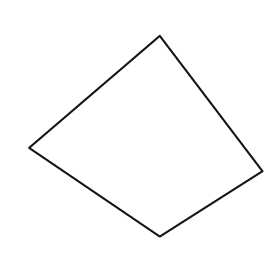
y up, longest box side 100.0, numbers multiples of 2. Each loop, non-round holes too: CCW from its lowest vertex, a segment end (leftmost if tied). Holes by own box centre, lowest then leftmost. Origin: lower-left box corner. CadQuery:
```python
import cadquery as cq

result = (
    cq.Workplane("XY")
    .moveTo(56.0, 0.0)
    .lineTo(100.0, 28.0)
    .lineTo(56.0, 86.0)
    .lineTo(0.0, 38.0)
    .close()
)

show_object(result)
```